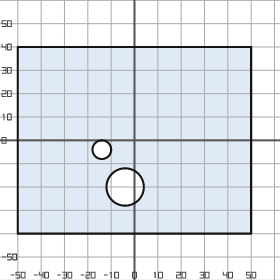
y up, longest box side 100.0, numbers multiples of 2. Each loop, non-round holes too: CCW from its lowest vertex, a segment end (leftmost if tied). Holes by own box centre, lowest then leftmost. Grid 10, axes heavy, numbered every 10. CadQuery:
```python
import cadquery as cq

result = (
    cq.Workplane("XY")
    .moveTo(-50.0, -40.0)
    .lineTo(50.0, -40.0)
    .lineTo(50.0, 40.0)
    .lineTo(-50.0, 40.0)
    .close()
    .moveTo(-4.0, -20.0)
    .circle(8.0)
    .moveTo(-14.0, -4.0)
    .circle(4.0)
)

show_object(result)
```